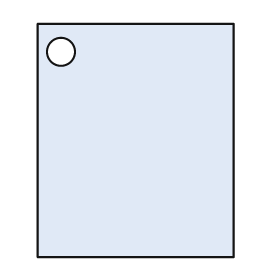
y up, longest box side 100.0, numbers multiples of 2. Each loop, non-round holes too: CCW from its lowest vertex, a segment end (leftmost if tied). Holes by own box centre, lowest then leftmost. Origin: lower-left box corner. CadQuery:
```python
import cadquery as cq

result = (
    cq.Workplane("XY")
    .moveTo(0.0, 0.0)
    .lineTo(84.0, 0.0)
    .lineTo(84.0, 100.0)
    .lineTo(0.0, 100.0)
    .close()
    .moveTo(10.0, 88.0)
    .circle(6.0)
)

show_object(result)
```